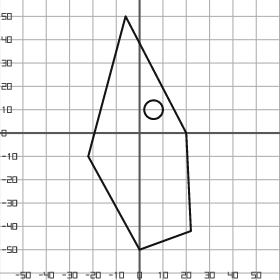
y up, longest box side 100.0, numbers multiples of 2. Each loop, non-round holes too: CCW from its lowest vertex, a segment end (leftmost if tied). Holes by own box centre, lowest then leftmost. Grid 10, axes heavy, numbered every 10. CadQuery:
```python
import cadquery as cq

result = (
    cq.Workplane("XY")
    .moveTo(0.0, -50.0)
    .lineTo(22.0, -42.0)
    .lineTo(20.0, 0.0)
    .lineTo(-6.0, 50.0)
    .lineTo(-22.0, -10.0)
    .close()
    .moveTo(6.0, 10.0)
    .circle(4.0)
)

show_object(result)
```